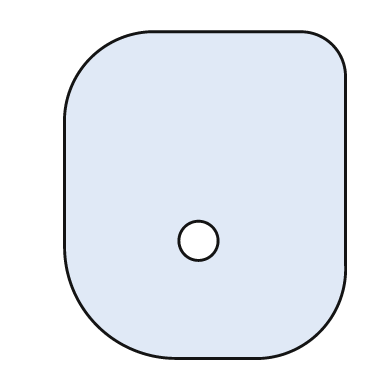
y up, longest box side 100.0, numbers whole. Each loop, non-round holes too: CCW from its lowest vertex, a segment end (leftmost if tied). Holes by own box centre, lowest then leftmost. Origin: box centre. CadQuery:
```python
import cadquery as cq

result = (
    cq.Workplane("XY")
    .moveTo(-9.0, -50.0)
    .lineTo(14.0, -50.0)
    .threePointArc((35.0, -42.0), (43.0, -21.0))
    .lineTo(43.0, 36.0)
    .threePointArc((39.0, 46.0), (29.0, 50.0))
    .lineTo(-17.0, 50.0)
    .threePointArc((-35.0, 42.0), (-43.0, 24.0))
    .lineTo(-43.0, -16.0)
    .threePointArc((-33.0, -40.0), (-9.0, -50.0))
    .close()
    .moveTo(-2.0, -14.0)
    .circle(6.0)
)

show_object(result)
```